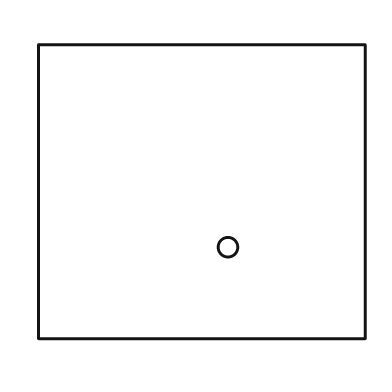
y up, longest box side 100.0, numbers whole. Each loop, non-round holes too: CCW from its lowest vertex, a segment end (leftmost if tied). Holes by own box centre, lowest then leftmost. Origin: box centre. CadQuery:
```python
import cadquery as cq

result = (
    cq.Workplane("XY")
    .moveTo(-50.0, -45.0)
    .lineTo(50.0, -45.0)
    .lineTo(50.0, 45.0)
    .lineTo(-50.0, 45.0)
    .close()
    .moveTo(8.0, -17.0)
    .circle(3.0)
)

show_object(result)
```